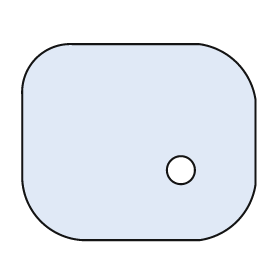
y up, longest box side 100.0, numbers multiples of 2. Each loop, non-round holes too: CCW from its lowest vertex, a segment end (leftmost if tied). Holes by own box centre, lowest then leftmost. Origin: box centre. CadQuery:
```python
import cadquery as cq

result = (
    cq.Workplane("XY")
    .moveTo(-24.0, -42.0)
    .lineTo(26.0, -42.0)
    .threePointArc((42.0, -34.0), (50.0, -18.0))
    .lineTo(50.0, 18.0)
    .threePointArc((42.0, 34.0), (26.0, 42.0))
    .lineTo(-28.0, 42.0)
    .threePointArc((-44.0, 36.0), (-50.0, 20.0))
    .lineTo(-50.0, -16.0)
    .threePointArc((-42.0, -34.0), (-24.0, -42.0))
    .close()
    .moveTo(18.0, -12.0)
    .circle(6.0)
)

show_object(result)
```